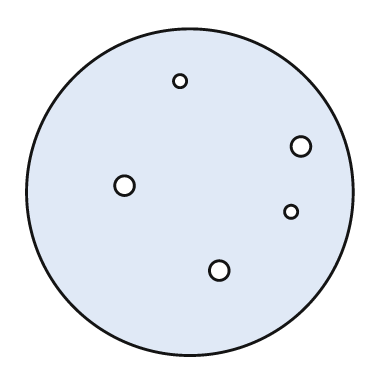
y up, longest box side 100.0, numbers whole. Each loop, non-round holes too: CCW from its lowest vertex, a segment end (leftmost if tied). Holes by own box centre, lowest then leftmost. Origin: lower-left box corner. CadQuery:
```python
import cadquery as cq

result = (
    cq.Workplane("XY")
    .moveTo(50.0, 50.0)
    .circle(50.0)
    .moveTo(59.0, 26.0)
    .circle(3.0)
    .moveTo(81.0, 44.0)
    .circle(2.0)
    .moveTo(30.0, 52.0)
    .circle(3.0)
    .moveTo(84.0, 64.0)
    .circle(3.0)
    .moveTo(47.0, 84.0)
    .circle(2.0)
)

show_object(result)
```